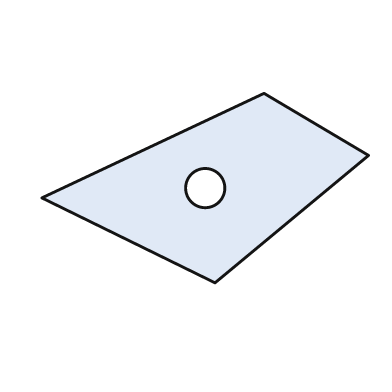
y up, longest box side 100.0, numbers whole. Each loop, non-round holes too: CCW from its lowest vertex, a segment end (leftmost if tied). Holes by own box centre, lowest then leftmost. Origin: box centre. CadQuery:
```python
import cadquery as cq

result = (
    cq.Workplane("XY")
    .moveTo(3.0, -29.0)
    .lineTo(50.0, 10.0)
    .lineTo(18.0, 29.0)
    .lineTo(-50.0, -3.0)
    .close()
    .moveTo(0.0, 0.0)
    .circle(6.0)
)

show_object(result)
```